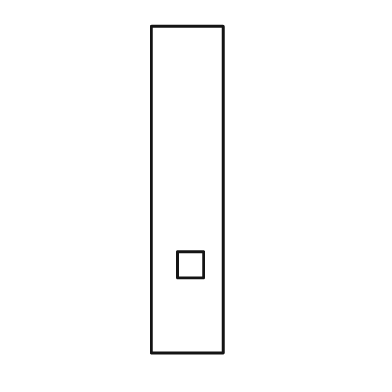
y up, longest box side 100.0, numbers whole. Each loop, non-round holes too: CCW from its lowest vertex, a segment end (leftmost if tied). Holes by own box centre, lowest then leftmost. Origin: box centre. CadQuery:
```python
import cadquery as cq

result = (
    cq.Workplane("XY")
    .moveTo(-11.0, -50.0)
    .lineTo(11.0, -50.0)
    .lineTo(11.0, 50.0)
    .lineTo(-11.0, 50.0)
    .close()
    .moveTo(-3.0, -27.0)
    .lineTo(5.0, -27.0)
    .lineTo(5.0, -19.0)
    .lineTo(-3.0, -19.0)
    .close()
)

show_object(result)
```